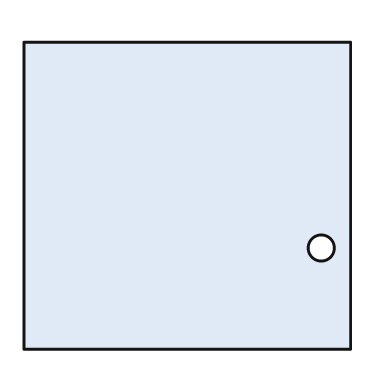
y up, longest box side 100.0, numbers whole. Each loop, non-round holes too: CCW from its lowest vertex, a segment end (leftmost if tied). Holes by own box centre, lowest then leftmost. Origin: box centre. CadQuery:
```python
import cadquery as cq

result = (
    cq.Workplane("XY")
    .moveTo(-50.0, -47.0)
    .lineTo(50.0, -47.0)
    .lineTo(50.0, 47.0)
    .lineTo(-50.0, 47.0)
    .close()
    .moveTo(41.0, -16.0)
    .circle(4.0)
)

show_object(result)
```